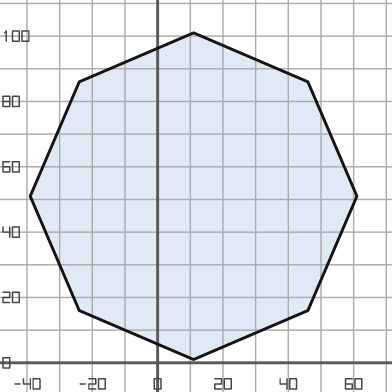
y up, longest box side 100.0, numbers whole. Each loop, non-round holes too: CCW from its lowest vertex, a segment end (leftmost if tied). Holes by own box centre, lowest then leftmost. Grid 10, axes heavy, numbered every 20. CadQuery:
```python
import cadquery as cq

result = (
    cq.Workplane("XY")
    .moveTo(11.0, 1.0)
    .lineTo(46.0, 16.0)
    .lineTo(61.0, 51.0)
    .lineTo(46.0, 86.0)
    .lineTo(11.0, 101.0)
    .lineTo(-24.0, 86.0)
    .lineTo(-39.0, 51.0)
    .lineTo(-24.0, 16.0)
    .close()
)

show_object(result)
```